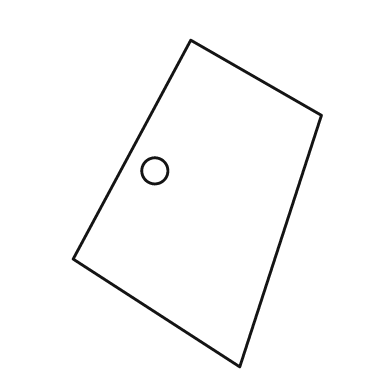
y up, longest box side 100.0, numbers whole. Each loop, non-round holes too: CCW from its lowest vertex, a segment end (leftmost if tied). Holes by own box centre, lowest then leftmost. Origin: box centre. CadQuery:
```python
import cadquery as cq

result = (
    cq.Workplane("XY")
    .moveTo(13.0, -50.0)
    .lineTo(38.0, 27.0)
    .lineTo(-2.0, 50.0)
    .lineTo(-38.0, -17.0)
    .close()
    .moveTo(-13.0, 10.0)
    .circle(4.0)
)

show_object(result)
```